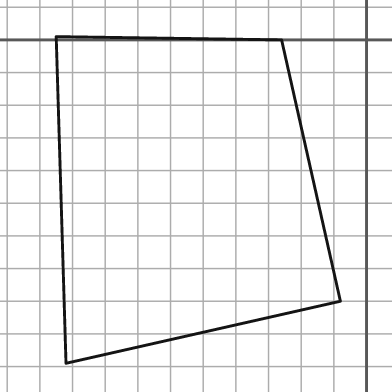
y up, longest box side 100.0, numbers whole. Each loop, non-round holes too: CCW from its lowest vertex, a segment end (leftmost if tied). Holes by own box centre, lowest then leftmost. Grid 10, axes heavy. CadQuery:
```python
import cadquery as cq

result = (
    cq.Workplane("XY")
    .moveTo(-92.0, -99.0)
    .lineTo(-8.0, -80.0)
    .lineTo(-26.0, 0.0)
    .lineTo(-95.0, 1.0)
    .close()
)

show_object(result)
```